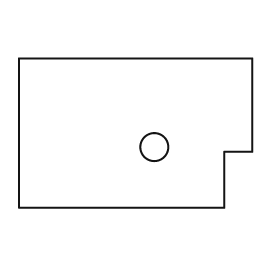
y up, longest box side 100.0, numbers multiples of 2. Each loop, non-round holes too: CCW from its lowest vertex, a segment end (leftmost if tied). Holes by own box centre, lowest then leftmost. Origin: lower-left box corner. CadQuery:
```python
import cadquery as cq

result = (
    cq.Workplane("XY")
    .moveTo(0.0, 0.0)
    .lineTo(88.0, 0.0)
    .lineTo(88.0, 24.0)
    .lineTo(100.0, 24.0)
    .lineTo(100.0, 64.0)
    .lineTo(0.0, 64.0)
    .close()
    .moveTo(58.0, 26.0)
    .circle(6.0)
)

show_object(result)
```